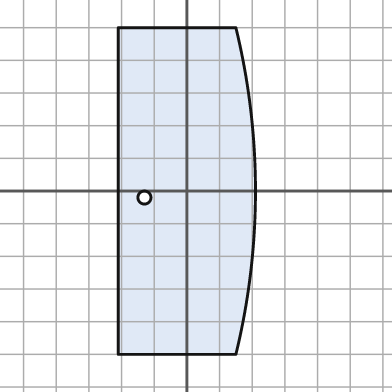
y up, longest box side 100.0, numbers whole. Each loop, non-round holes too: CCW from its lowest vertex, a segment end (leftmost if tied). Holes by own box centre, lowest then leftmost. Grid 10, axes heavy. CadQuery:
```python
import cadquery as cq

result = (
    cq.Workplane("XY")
    .moveTo(-21.0, -50.0)
    .lineTo(15.0, -50.0)
    .threePointArc((21.0, 0.0), (15.0, 50.0))
    .lineTo(-21.0, 50.0)
    .close()
    .moveTo(-13.0, -2.0)
    .circle(2.0)
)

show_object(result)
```